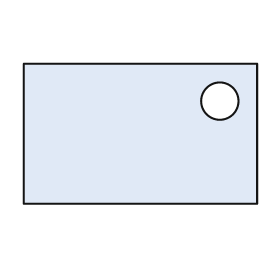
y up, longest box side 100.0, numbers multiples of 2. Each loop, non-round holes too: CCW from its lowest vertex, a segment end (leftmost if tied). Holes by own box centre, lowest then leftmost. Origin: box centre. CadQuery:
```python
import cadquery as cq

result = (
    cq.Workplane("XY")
    .moveTo(-50.0, -30.0)
    .lineTo(50.0, -30.0)
    .lineTo(50.0, 30.0)
    .lineTo(-50.0, 30.0)
    .close()
    .moveTo(34.0, 14.0)
    .circle(8.0)
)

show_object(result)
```